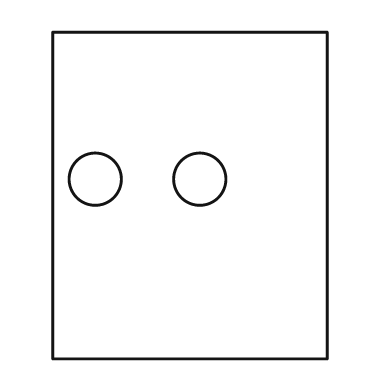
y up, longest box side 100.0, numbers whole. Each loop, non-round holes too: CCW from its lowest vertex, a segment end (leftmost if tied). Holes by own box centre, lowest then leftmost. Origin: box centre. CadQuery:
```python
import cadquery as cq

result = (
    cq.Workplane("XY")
    .moveTo(-42.0, -50.0)
    .lineTo(42.0, -50.0)
    .lineTo(42.0, 50.0)
    .lineTo(-42.0, 50.0)
    .close()
    .moveTo(-29.0, 5.0)
    .circle(8.0)
    .moveTo(3.0, 5.0)
    .circle(8.0)
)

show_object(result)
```